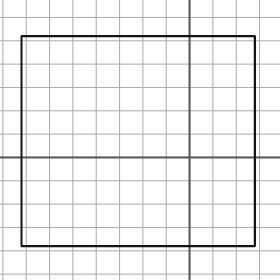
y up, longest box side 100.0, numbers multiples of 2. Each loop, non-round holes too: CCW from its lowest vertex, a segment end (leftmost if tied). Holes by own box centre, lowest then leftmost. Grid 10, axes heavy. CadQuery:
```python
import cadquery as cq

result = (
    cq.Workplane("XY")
    .moveTo(-72.0, -38.0)
    .lineTo(28.0, -38.0)
    .lineTo(28.0, 52.0)
    .lineTo(-72.0, 52.0)
    .close()
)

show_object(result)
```